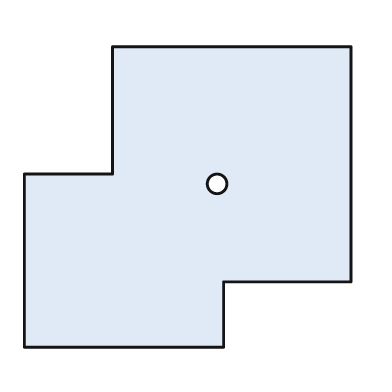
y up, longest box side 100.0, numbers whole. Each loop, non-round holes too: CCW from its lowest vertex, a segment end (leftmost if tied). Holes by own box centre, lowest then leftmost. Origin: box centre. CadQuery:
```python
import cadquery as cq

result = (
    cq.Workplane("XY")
    .moveTo(-50.0, -46.0)
    .lineTo(11.0, -46.0)
    .lineTo(11.0, -26.0)
    .lineTo(50.0, -26.0)
    .lineTo(50.0, 46.0)
    .lineTo(-23.0, 46.0)
    .lineTo(-23.0, 7.0)
    .lineTo(-50.0, 7.0)
    .close()
    .moveTo(9.0, 4.0)
    .circle(3.0)
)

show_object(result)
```